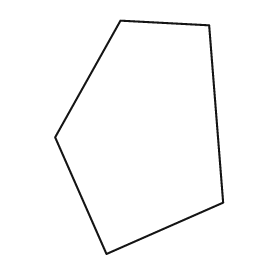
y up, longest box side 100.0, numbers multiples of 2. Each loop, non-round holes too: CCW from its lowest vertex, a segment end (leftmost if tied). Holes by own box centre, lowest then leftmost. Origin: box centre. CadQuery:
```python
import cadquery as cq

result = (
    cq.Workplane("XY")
    .moveTo(-14.0, -50.0)
    .lineTo(36.0, -28.0)
    .lineTo(30.0, 48.0)
    .lineTo(-8.0, 50.0)
    .lineTo(-36.0, 0.0)
    .close()
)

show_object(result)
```